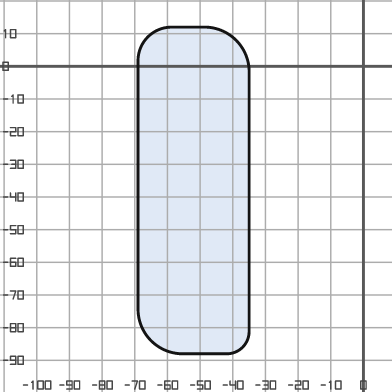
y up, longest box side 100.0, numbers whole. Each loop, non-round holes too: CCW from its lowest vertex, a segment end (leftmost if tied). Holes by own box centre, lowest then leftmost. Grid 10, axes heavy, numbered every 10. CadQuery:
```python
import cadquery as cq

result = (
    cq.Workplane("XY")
    .moveTo(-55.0, -88.0)
    .lineTo(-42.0, -88.0)
    .threePointArc((-37.0, -86.0), (-35.0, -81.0))
    .lineTo(-35.0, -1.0)
    .threePointArc((-39.0, 8.0), (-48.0, 12.0))
    .lineTo(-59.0, 12.0)
    .threePointArc((-66.0, 9.0), (-69.0, 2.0))
    .lineTo(-69.0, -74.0)
    .threePointArc((-65.0, -84.0), (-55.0, -88.0))
    .close()
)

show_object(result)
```